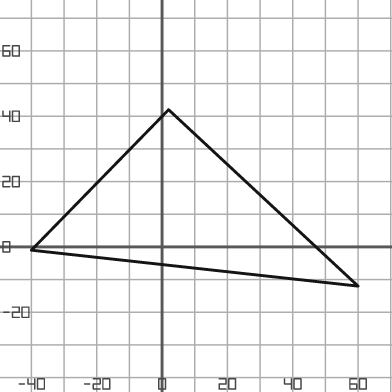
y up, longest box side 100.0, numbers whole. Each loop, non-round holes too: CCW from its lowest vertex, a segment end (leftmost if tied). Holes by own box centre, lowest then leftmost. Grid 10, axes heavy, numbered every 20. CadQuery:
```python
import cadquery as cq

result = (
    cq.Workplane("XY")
    .moveTo(60.0, -12.0)
    .lineTo(2.0, 42.0)
    .lineTo(-40.0, -1.0)
    .close()
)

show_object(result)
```